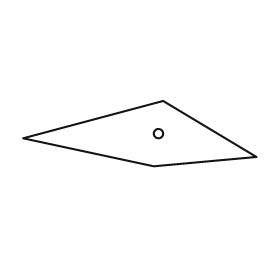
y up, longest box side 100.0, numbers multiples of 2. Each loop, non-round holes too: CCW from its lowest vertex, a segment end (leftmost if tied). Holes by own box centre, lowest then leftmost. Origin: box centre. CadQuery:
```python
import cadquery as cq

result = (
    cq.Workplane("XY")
    .moveTo(6.0, -14.0)
    .lineTo(50.0, -10.0)
    .lineTo(10.0, 14.0)
    .lineTo(-50.0, -2.0)
    .close()
    .moveTo(8.0, 0.0)
    .circle(2.0)
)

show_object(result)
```